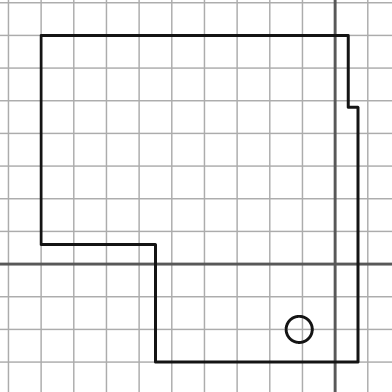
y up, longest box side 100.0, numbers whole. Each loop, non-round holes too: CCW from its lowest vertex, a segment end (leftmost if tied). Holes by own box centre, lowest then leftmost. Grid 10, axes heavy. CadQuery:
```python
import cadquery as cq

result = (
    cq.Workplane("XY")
    .moveTo(-55.0, -30.0)
    .lineTo(7.0, -30.0)
    .lineTo(7.0, 48.0)
    .lineTo(4.0, 48.0)
    .lineTo(4.0, 70.0)
    .lineTo(-90.0, 70.0)
    .lineTo(-90.0, 6.0)
    .lineTo(-55.0, 6.0)
    .close()
    .moveTo(-11.0, -20.0)
    .circle(4.0)
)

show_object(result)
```